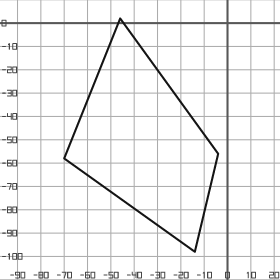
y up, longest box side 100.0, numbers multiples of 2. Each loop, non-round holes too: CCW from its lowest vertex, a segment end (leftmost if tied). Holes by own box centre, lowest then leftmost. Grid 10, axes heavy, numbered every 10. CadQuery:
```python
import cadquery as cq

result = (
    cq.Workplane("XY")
    .moveTo(-14.0, -98.0)
    .lineTo(-4.0, -56.0)
    .lineTo(-46.0, 2.0)
    .lineTo(-70.0, -58.0)
    .close()
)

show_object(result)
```